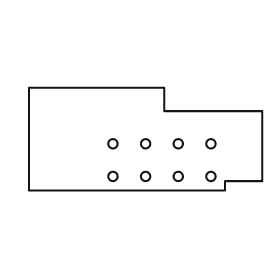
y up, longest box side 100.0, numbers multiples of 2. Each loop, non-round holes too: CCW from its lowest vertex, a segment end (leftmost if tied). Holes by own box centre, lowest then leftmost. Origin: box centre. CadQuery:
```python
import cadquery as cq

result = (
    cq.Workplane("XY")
    .moveTo(-50.0, -22.0)
    .lineTo(34.0, -22.0)
    .lineTo(34.0, -18.0)
    .lineTo(50.0, -18.0)
    .lineTo(50.0, 12.0)
    .lineTo(8.0, 12.0)
    .lineTo(8.0, 22.0)
    .lineTo(-50.0, 22.0)
    .close()
    .moveTo(-14.0, -16.0)
    .circle(2.0)
    .moveTo(0.0, -16.0)
    .circle(2.0)
    .moveTo(14.0, -16.0)
    .circle(2.0)
    .moveTo(28.0, -16.0)
    .circle(2.0)
    .moveTo(-14.0, -2.0)
    .circle(2.0)
    .moveTo(0.0, -2.0)
    .circle(2.0)
    .moveTo(14.0, -2.0)
    .circle(2.0)
    .moveTo(28.0, -2.0)
    .circle(2.0)
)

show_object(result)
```